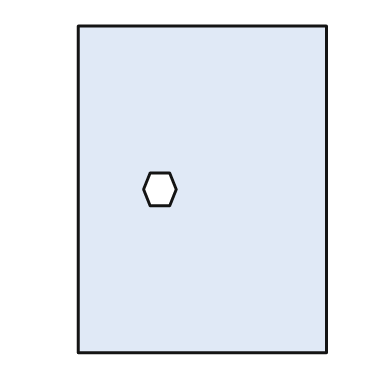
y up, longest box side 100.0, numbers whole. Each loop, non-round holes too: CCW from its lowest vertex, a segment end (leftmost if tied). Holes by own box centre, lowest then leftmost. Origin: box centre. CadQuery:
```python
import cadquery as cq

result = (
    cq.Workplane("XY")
    .moveTo(-38.0, -50.0)
    .lineTo(38.0, -50.0)
    .lineTo(38.0, 50.0)
    .lineTo(-38.0, 50.0)
    .close()
    .moveTo(-16.0, -5.0)
    .lineTo(-10.0, -5.0)
    .lineTo(-8.0, 0.0)
    .lineTo(-10.0, 5.0)
    .lineTo(-16.0, 5.0)
    .lineTo(-18.0, 0.0)
    .close()
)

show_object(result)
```